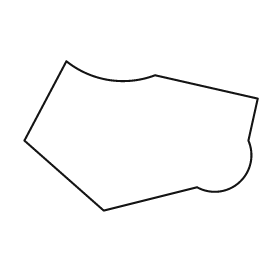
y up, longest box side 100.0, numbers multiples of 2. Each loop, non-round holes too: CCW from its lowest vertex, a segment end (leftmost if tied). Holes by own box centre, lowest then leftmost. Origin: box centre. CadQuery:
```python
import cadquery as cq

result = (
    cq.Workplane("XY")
    .moveTo(-16.0, -32.0)
    .lineTo(24.0, -22.0)
    .threePointArc((42.0, -20.0), (46.0, -2.0))
    .lineTo(50.0, 16.0)
    .lineTo(6.0, 26.0)
    .threePointArc((-14.0, 24.0), (-32.0, 32.0))
    .lineTo(-50.0, -2.0)
    .close()
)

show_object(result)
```